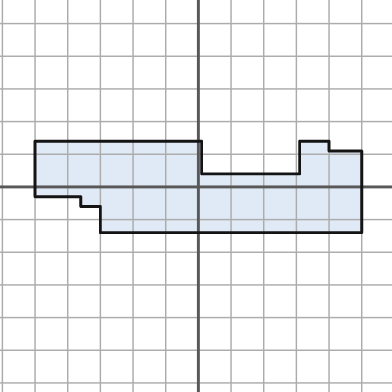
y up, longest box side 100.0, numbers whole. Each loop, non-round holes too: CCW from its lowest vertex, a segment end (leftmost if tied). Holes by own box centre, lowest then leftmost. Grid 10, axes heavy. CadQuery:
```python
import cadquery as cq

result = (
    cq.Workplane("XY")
    .moveTo(-30.0, -14.0)
    .lineTo(50.0, -14.0)
    .lineTo(50.0, 11.0)
    .lineTo(40.0, 11.0)
    .lineTo(40.0, 14.0)
    .lineTo(31.0, 14.0)
    .lineTo(31.0, 4.0)
    .lineTo(1.0, 4.0)
    .lineTo(1.0, 14.0)
    .lineTo(-50.0, 14.0)
    .lineTo(-50.0, -3.0)
    .lineTo(-36.0, -3.0)
    .lineTo(-36.0, -6.0)
    .lineTo(-30.0, -6.0)
    .close()
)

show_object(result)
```